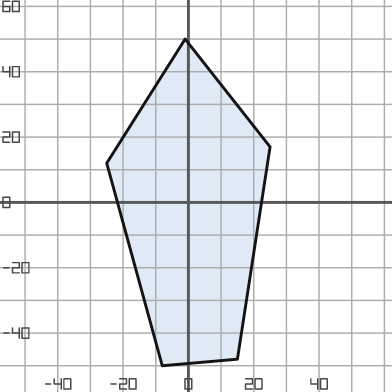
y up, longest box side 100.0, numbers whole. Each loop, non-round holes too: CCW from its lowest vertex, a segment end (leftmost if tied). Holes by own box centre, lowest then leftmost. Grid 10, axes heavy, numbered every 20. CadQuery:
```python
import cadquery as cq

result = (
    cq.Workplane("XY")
    .moveTo(-8.0, -50.0)
    .lineTo(15.0, -48.0)
    .lineTo(25.0, 17.0)
    .lineTo(-1.0, 50.0)
    .lineTo(-25.0, 12.0)
    .close()
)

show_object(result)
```